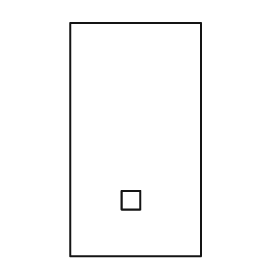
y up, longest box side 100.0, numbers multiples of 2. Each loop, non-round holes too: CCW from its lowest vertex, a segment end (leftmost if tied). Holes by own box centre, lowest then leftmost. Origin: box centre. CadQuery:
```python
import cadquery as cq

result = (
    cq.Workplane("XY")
    .moveTo(-28.0, -50.0)
    .lineTo(28.0, -50.0)
    .lineTo(28.0, 50.0)
    .lineTo(-28.0, 50.0)
    .close()
    .moveTo(-6.0, -30.0)
    .lineTo(2.0, -30.0)
    .lineTo(2.0, -22.0)
    .lineTo(-6.0, -22.0)
    .close()
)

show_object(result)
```